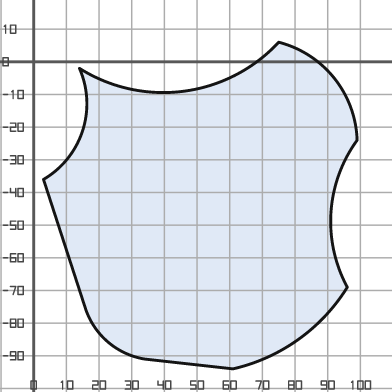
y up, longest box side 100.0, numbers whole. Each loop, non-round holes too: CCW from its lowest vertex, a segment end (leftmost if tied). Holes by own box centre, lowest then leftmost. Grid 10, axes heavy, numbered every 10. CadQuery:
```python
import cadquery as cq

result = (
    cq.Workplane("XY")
    .moveTo(61.0, -94.0)
    .threePointArc((81.0, -85.0), (96.0, -69.0))
    .threePointArc((91.0, -46.0), (99.0, -24.0))
    .threePointArc((92.0, -5.0), (75.0, 6.0))
    .threePointArc((46.0, -9.0), (14.0, -2.0))
    .threePointArc((15.0, -21.0), (3.0, -36.0))
    .lineTo(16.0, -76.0)
    .threePointArc((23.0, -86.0), (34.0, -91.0))
    .close()
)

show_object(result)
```